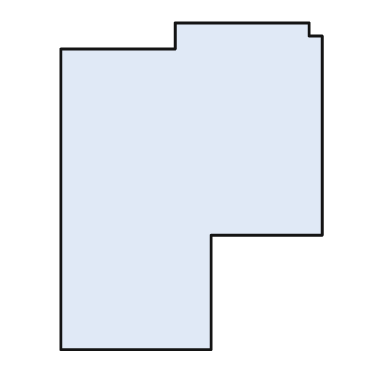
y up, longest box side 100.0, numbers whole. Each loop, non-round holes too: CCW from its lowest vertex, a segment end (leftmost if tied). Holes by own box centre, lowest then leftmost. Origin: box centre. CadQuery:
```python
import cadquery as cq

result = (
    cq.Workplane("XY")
    .moveTo(-40.0, -50.0)
    .lineTo(6.0, -50.0)
    .lineTo(6.0, -15.0)
    .lineTo(40.0, -15.0)
    .lineTo(40.0, 46.0)
    .lineTo(36.0, 46.0)
    .lineTo(36.0, 50.0)
    .lineTo(-5.0, 50.0)
    .lineTo(-5.0, 42.0)
    .lineTo(-40.0, 42.0)
    .close()
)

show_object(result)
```